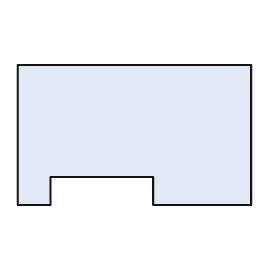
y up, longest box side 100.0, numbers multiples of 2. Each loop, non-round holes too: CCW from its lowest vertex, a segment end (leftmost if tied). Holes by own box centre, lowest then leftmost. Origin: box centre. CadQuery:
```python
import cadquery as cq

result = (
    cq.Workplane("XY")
    .moveTo(-50.0, -30.0)
    .lineTo(-36.0, -30.0)
    .lineTo(-36.0, -18.0)
    .lineTo(8.0, -18.0)
    .lineTo(8.0, -30.0)
    .lineTo(50.0, -30.0)
    .lineTo(50.0, 30.0)
    .lineTo(-50.0, 30.0)
    .close()
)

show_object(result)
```